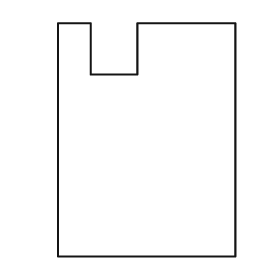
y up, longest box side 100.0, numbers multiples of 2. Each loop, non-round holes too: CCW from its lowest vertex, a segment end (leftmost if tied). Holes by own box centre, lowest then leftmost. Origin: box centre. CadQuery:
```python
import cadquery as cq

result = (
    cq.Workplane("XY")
    .moveTo(-38.0, -50.0)
    .lineTo(38.0, -50.0)
    .lineTo(38.0, 50.0)
    .lineTo(-4.0, 50.0)
    .lineTo(-4.0, 28.0)
    .lineTo(-24.0, 28.0)
    .lineTo(-24.0, 50.0)
    .lineTo(-38.0, 50.0)
    .close()
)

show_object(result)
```